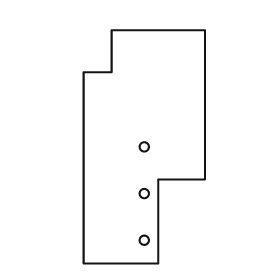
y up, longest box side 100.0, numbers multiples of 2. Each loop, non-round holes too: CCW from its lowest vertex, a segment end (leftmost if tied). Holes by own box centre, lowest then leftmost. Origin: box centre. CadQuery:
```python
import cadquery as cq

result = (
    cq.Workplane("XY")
    .moveTo(-26.0, -50.0)
    .lineTo(6.0, -50.0)
    .lineTo(6.0, -14.0)
    .lineTo(26.0, -14.0)
    .lineTo(26.0, 50.0)
    .lineTo(-14.0, 50.0)
    .lineTo(-14.0, 32.0)
    .lineTo(-26.0, 32.0)
    .close()
    .moveTo(0.0, -40.0)
    .circle(2.0)
    .moveTo(0.0, -20.0)
    .circle(2.0)
    .moveTo(0.0, 0.0)
    .circle(2.0)
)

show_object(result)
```